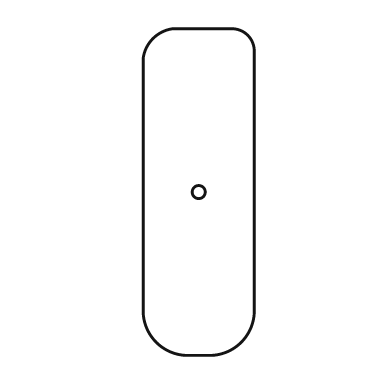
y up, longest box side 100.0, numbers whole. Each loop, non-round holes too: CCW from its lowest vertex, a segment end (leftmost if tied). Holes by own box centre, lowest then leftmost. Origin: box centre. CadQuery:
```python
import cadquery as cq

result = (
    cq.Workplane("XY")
    .moveTo(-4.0, -50.0)
    .lineTo(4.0, -50.0)
    .threePointArc((13.0, -46.0), (17.0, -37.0))
    .lineTo(17.0, 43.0)
    .threePointArc((15.0, 48.0), (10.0, 50.0))
    .lineTo(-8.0, 50.0)
    .threePointArc((-14.0, 47.0), (-17.0, 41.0))
    .lineTo(-17.0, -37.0)
    .threePointArc((-13.0, -46.0), (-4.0, -50.0))
    .close()
    .moveTo(0.0, 0.0)
    .circle(2.0)
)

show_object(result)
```